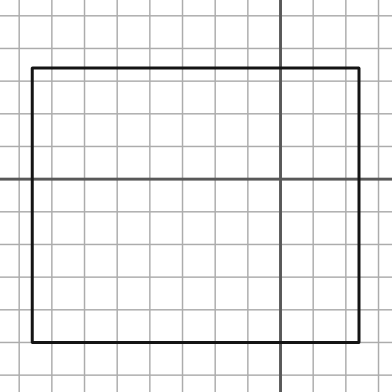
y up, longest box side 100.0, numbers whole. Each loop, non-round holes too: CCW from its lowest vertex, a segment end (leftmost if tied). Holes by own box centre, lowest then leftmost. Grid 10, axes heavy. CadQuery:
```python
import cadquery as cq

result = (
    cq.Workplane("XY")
    .moveTo(-76.0, -50.0)
    .lineTo(24.0, -50.0)
    .lineTo(24.0, 34.0)
    .lineTo(-76.0, 34.0)
    .close()
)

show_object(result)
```